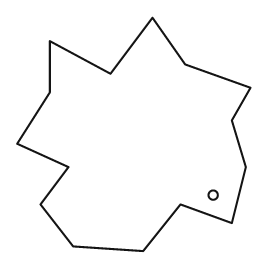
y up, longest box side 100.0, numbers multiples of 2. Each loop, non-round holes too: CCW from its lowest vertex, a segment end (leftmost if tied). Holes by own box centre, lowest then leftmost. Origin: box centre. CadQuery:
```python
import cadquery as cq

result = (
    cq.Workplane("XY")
    .moveTo(4.0, -50.0)
    .lineTo(20.0, -30.0)
    .lineTo(42.0, -38.0)
    .lineTo(48.0, -14.0)
    .lineTo(42.0, 6.0)
    .lineTo(50.0, 20.0)
    .lineTo(22.0, 30.0)
    .lineTo(8.0, 50.0)
    .lineTo(-10.0, 26.0)
    .lineTo(-36.0, 40.0)
    .lineTo(-36.0, 18.0)
    .lineTo(-50.0, -4.0)
    .lineTo(-28.0, -14.0)
    .lineTo(-40.0, -30.0)
    .lineTo(-26.0, -48.0)
    .close()
    .moveTo(34.0, -26.0)
    .circle(2.0)
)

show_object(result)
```